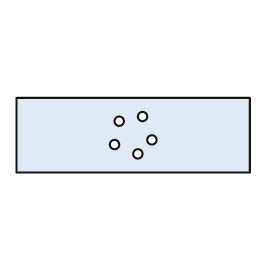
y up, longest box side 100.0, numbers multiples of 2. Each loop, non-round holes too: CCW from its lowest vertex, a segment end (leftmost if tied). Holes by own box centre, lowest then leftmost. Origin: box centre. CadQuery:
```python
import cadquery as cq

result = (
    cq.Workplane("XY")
    .moveTo(-50.0, -16.0)
    .lineTo(50.0, -16.0)
    .lineTo(50.0, 16.0)
    .lineTo(-50.0, 16.0)
    .close()
    .moveTo(2.0, -8.0)
    .circle(2.0)
    .moveTo(-8.0, -4.0)
    .circle(2.0)
    .moveTo(8.0, -2.0)
    .circle(2.0)
    .moveTo(-6.0, 6.0)
    .circle(2.0)
    .moveTo(4.0, 8.0)
    .circle(2.0)
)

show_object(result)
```